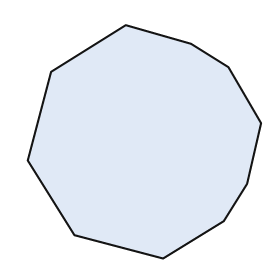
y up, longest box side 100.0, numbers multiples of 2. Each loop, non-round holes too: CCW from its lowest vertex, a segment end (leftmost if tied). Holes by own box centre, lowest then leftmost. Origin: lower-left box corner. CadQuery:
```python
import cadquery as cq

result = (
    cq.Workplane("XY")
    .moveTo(58.0, 0.0)
    .lineTo(84.0, 16.0)
    .lineTo(94.0, 32.0)
    .lineTo(100.0, 58.0)
    .lineTo(86.0, 82.0)
    .lineTo(70.0, 92.0)
    .lineTo(42.0, 100.0)
    .lineTo(10.0, 80.0)
    .lineTo(0.0, 42.0)
    .lineTo(20.0, 10.0)
    .close()
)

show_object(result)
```